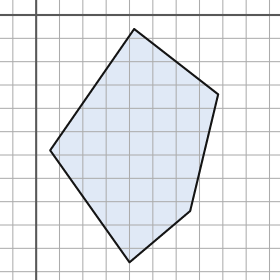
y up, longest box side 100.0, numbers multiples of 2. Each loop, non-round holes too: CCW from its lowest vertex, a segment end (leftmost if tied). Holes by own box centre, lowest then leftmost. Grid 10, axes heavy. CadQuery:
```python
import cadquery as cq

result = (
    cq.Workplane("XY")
    .moveTo(40.0, -106.0)
    .lineTo(66.0, -84.0)
    .lineTo(78.0, -34.0)
    .lineTo(42.0, -6.0)
    .lineTo(6.0, -58.0)
    .close()
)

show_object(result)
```